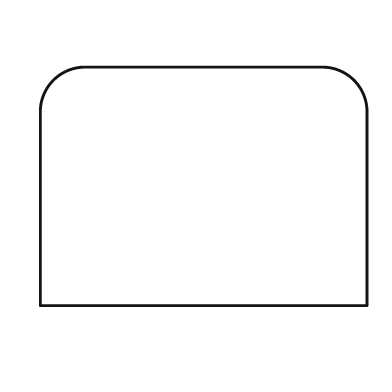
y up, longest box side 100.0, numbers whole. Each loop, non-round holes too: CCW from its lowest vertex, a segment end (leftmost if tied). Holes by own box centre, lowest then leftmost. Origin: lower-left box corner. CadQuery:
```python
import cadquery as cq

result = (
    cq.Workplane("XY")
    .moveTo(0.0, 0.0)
    .lineTo(100.0, 0.0)
    .lineTo(100.0, 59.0)
    .threePointArc((96.0, 69.0), (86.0, 73.0))
    .lineTo(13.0, 73.0)
    .threePointArc((4.0, 69.0), (0.0, 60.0))
    .close()
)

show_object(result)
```